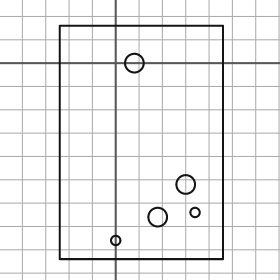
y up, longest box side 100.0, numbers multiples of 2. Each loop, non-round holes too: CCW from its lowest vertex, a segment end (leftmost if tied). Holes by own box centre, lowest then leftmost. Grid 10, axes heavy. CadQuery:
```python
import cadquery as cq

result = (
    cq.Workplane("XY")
    .moveTo(-24.0, -84.0)
    .lineTo(46.0, -84.0)
    .lineTo(46.0, 16.0)
    .lineTo(-24.0, 16.0)
    .close()
    .moveTo(0.0, -76.0)
    .circle(2.0)
    .moveTo(18.0, -66.0)
    .circle(4.0)
    .moveTo(34.0, -64.0)
    .circle(2.0)
    .moveTo(30.0, -52.0)
    .circle(4.0)
    .moveTo(8.0, 0.0)
    .circle(4.0)
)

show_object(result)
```